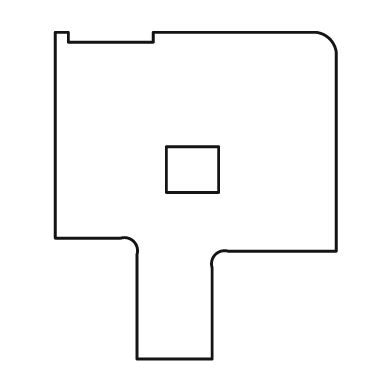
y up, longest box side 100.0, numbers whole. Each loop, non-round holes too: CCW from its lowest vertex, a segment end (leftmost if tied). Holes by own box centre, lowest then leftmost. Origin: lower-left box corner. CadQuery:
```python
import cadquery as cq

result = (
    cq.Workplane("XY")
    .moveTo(25.0, 0.0)
    .lineTo(48.0, 0.0)
    .lineTo(48.0, 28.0)
    .threePointArc((49.0, 32.0), (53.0, 33.0))
    .lineTo(86.0, 33.0)
    .lineTo(86.0, 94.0)
    .threePointArc((84.0, 98.0), (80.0, 100.0))
    .lineTo(30.0, 100.0)
    .lineTo(30.0, 97.0)
    .lineTo(4.0, 97.0)
    .lineTo(4.0, 100.0)
    .lineTo(0.0, 100.0)
    .lineTo(0.0, 37.0)
    .lineTo(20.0, 37.0)
    .threePointArc((24.0, 36.0), (25.0, 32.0))
    .close()
    .moveTo(34.0, 51.0)
    .lineTo(50.0, 51.0)
    .lineTo(50.0, 65.0)
    .lineTo(34.0, 65.0)
    .close()
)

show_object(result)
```